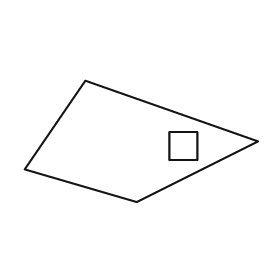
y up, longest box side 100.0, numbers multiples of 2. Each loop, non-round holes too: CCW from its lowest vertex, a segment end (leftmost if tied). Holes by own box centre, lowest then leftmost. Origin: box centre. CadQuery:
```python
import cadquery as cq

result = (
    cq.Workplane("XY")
    .moveTo(-2.0, -26.0)
    .lineTo(50.0, 0.0)
    .lineTo(-24.0, 26.0)
    .lineTo(-50.0, -12.0)
    .close()
    .moveTo(12.0, -8.0)
    .lineTo(24.0, -8.0)
    .lineTo(24.0, 4.0)
    .lineTo(12.0, 4.0)
    .close()
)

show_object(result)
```